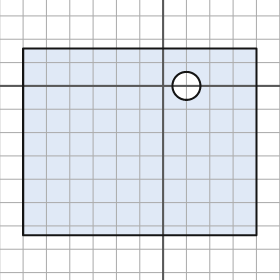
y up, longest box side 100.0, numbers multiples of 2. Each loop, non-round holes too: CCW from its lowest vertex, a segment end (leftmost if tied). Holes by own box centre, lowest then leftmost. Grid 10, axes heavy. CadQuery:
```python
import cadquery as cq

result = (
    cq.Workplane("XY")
    .moveTo(-60.0, -64.0)
    .lineTo(40.0, -64.0)
    .lineTo(40.0, 16.0)
    .lineTo(-60.0, 16.0)
    .close()
    .moveTo(10.0, 0.0)
    .circle(6.0)
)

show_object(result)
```